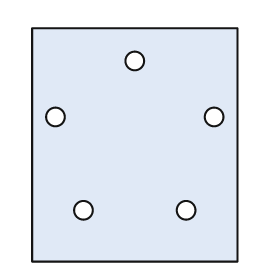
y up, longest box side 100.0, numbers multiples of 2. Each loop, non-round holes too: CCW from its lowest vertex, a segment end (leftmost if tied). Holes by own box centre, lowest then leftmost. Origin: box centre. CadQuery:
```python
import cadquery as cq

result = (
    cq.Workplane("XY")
    .moveTo(-44.0, -50.0)
    .lineTo(44.0, -50.0)
    .lineTo(44.0, 50.0)
    .lineTo(-44.0, 50.0)
    .close()
    .moveTo(-22.0, -28.0)
    .circle(4.0)
    .moveTo(22.0, -28.0)
    .circle(4.0)
    .moveTo(-34.0, 12.0)
    .circle(4.0)
    .moveTo(34.0, 12.0)
    .circle(4.0)
    .moveTo(0.0, 36.0)
    .circle(4.0)
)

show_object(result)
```